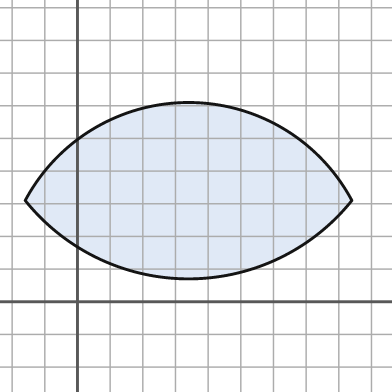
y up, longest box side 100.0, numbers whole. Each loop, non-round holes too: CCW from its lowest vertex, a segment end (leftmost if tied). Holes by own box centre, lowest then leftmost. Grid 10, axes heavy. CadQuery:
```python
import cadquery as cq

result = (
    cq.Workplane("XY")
    .moveTo(-16.0, 31.0)
    .threePointArc((34.0, 7.0), (84.0, 31.0))
    .threePointArc((34.0, 61.0), (-16.0, 31.0))
    .close()
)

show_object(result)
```